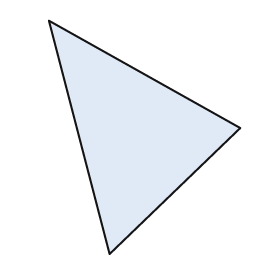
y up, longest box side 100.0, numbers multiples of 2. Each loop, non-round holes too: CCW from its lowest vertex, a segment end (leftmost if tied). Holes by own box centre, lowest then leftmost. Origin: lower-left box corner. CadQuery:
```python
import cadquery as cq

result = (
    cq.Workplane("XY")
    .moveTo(26.0, 0.0)
    .lineTo(82.0, 54.0)
    .lineTo(0.0, 100.0)
    .close()
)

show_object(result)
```